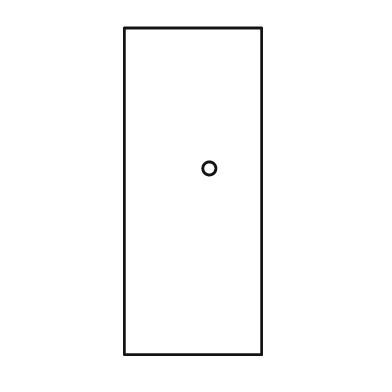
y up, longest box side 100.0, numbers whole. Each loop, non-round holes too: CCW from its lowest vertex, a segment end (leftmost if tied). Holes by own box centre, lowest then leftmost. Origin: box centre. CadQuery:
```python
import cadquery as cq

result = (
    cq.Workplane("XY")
    .moveTo(-21.0, -50.0)
    .lineTo(21.0, -50.0)
    .lineTo(21.0, 50.0)
    .lineTo(-21.0, 50.0)
    .close()
    .moveTo(5.0, 7.0)
    .circle(2.0)
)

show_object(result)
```